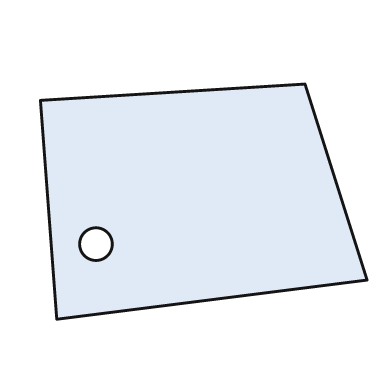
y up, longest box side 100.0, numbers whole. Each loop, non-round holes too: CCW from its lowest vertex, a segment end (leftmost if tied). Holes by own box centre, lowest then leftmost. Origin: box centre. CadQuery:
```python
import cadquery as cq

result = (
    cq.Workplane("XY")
    .moveTo(-45.0, -36.0)
    .lineTo(50.0, -24.0)
    .lineTo(31.0, 36.0)
    .lineTo(-50.0, 31.0)
    .close()
    .moveTo(-33.0, -13.0)
    .circle(5.0)
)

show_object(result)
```